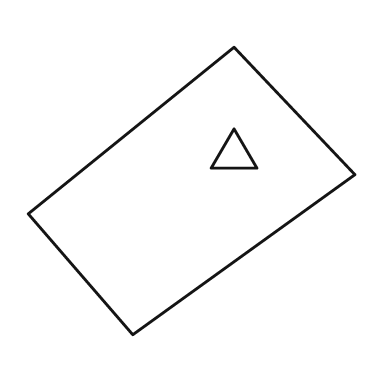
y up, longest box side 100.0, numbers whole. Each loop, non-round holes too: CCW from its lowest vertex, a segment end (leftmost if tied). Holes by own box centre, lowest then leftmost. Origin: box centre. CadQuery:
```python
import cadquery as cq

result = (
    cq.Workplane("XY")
    .moveTo(-18.0, -44.0)
    .lineTo(50.0, 5.0)
    .lineTo(13.0, 44.0)
    .lineTo(-50.0, -7.0)
    .close()
    .moveTo(6.0, 7.0)
    .lineTo(20.0, 7.0)
    .lineTo(13.0, 19.0)
    .close()
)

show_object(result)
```